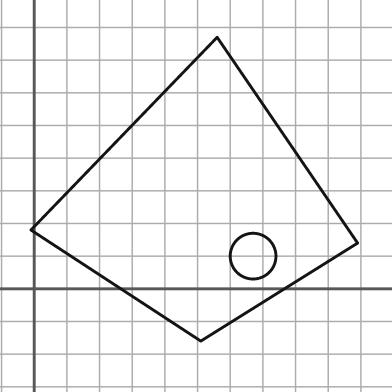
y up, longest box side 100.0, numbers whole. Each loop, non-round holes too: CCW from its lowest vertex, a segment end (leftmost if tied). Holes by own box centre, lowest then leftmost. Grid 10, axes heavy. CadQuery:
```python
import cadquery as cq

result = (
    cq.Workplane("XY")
    .moveTo(51.0, -16.0)
    .lineTo(99.0, 14.0)
    .lineTo(56.0, 77.0)
    .lineTo(-1.0, 18.0)
    .close()
    .moveTo(67.0, 10.0)
    .circle(7.0)
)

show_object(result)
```